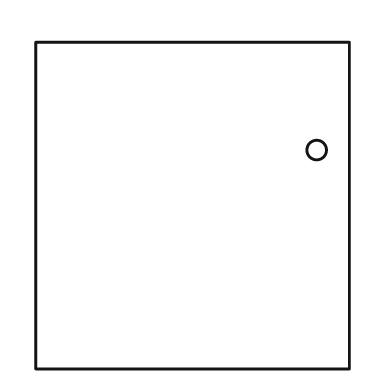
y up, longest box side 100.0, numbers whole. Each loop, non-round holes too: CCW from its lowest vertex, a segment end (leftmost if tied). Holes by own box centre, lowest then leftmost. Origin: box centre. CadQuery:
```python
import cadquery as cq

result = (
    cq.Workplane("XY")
    .moveTo(-48.0, -50.0)
    .lineTo(48.0, -50.0)
    .lineTo(48.0, 50.0)
    .lineTo(-48.0, 50.0)
    .close()
    .moveTo(38.0, 17.0)
    .circle(3.0)
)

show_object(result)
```